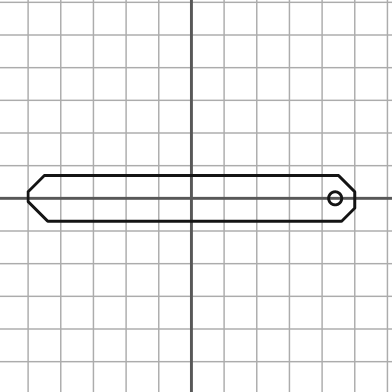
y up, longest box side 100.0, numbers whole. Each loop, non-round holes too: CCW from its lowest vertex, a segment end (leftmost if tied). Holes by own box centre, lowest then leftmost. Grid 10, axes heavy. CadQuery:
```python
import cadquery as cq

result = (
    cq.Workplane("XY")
    .moveTo(-44.0, -7.0)
    .lineTo(46.0, -7.0)
    .lineTo(50.0, -3.0)
    .lineTo(50.0, 2.0)
    .lineTo(45.0, 7.0)
    .lineTo(-45.0, 7.0)
    .lineTo(-50.0, 2.0)
    .lineTo(-50.0, -1.0)
    .close()
    .moveTo(44.0, 0.0)
    .circle(2.0)
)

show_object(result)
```